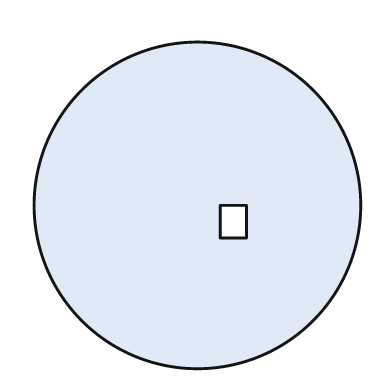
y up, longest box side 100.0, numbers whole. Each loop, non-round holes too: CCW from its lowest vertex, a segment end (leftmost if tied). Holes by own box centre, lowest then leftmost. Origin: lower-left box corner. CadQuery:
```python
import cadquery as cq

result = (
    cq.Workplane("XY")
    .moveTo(50.0, 50.0)
    .circle(50.0)
    .moveTo(57.0, 40.0)
    .lineTo(65.0, 40.0)
    .lineTo(65.0, 50.0)
    .lineTo(57.0, 50.0)
    .close()
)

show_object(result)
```